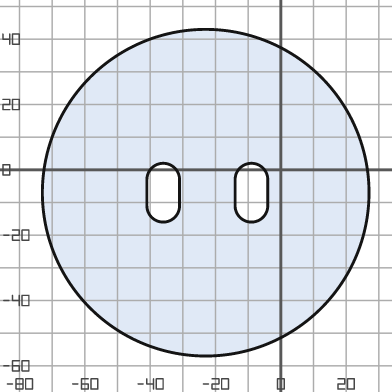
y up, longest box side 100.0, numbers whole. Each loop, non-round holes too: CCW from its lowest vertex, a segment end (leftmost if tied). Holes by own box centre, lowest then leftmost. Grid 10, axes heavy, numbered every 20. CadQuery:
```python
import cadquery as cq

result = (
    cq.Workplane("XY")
    .moveTo(-23.0, -7.0)
    .circle(50.0)
    .moveTo(-41.0, -11.0)
    .threePointArc((-36.0, -16.0), (-31.0, -11.0))
    .lineTo(-31.0, -3.0)
    .threePointArc((-36.0, 2.0), (-41.0, -3.0))
    .close()
    .moveTo(-14.0, -11.0)
    .threePointArc((-9.0, -16.0), (-4.0, -11.0))
    .lineTo(-4.0, -3.0)
    .threePointArc((-9.0, 2.0), (-14.0, -3.0))
    .close()
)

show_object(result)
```